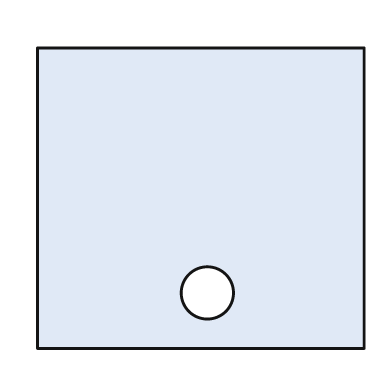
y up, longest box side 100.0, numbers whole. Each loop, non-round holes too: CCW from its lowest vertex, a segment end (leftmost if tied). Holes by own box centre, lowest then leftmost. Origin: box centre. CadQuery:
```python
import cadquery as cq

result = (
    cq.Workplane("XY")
    .moveTo(-50.0, -46.0)
    .lineTo(50.0, -46.0)
    .lineTo(50.0, 46.0)
    .lineTo(-50.0, 46.0)
    .close()
    .moveTo(2.0, -29.0)
    .circle(8.0)
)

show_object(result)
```